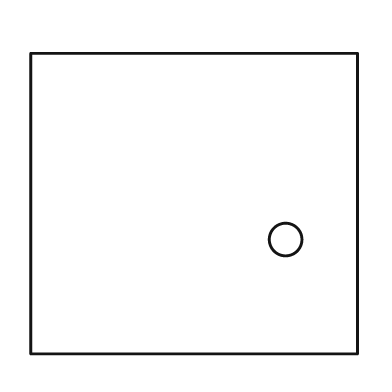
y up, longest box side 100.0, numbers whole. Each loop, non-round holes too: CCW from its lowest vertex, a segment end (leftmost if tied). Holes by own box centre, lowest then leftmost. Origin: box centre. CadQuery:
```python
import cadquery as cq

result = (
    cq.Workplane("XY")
    .moveTo(-50.0, -46.0)
    .lineTo(50.0, -46.0)
    .lineTo(50.0, 46.0)
    .lineTo(-50.0, 46.0)
    .close()
    .moveTo(28.0, -11.0)
    .circle(5.0)
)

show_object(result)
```